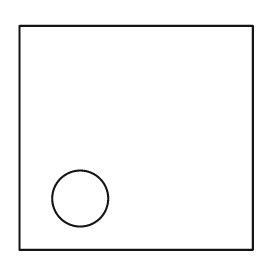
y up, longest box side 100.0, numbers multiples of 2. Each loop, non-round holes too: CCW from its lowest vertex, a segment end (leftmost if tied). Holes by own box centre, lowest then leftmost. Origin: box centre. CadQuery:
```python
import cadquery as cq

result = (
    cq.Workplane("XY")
    .moveTo(-50.0, -48.0)
    .lineTo(50.0, -48.0)
    .lineTo(50.0, 48.0)
    .lineTo(-50.0, 48.0)
    .close()
    .moveTo(-24.0, -26.0)
    .circle(12.0)
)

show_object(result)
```